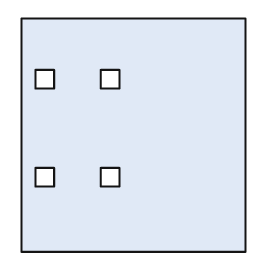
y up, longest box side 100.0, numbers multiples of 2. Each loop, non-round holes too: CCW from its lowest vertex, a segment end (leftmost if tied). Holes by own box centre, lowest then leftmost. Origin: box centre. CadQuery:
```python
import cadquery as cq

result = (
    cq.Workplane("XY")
    .moveTo(-48.0, -50.0)
    .lineTo(48.0, -50.0)
    .lineTo(48.0, 50.0)
    .lineTo(-48.0, 50.0)
    .close()
    .moveTo(-42.0, -22.0)
    .lineTo(-34.0, -22.0)
    .lineTo(-34.0, -14.0)
    .lineTo(-42.0, -14.0)
    .close()
    .moveTo(-14.0, -22.0)
    .lineTo(-6.0, -22.0)
    .lineTo(-6.0, -14.0)
    .lineTo(-14.0, -14.0)
    .close()
    .moveTo(-42.0, 20.0)
    .lineTo(-34.0, 20.0)
    .lineTo(-34.0, 28.0)
    .lineTo(-42.0, 28.0)
    .close()
    .moveTo(-14.0, 20.0)
    .lineTo(-6.0, 20.0)
    .lineTo(-6.0, 28.0)
    .lineTo(-14.0, 28.0)
    .close()
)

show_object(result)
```